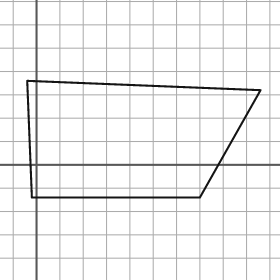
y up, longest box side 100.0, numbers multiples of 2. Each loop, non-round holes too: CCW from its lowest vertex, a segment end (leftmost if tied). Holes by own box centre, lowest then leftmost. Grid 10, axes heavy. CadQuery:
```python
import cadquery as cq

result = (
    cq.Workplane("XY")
    .moveTo(-2.0, -14.0)
    .lineTo(70.0, -14.0)
    .lineTo(96.0, 32.0)
    .lineTo(-4.0, 36.0)
    .close()
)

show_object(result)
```